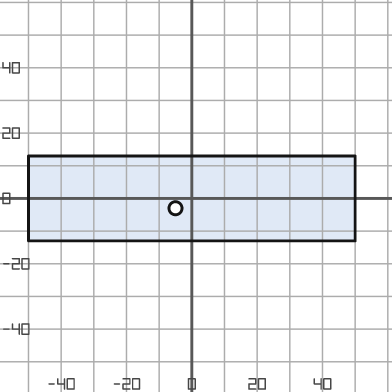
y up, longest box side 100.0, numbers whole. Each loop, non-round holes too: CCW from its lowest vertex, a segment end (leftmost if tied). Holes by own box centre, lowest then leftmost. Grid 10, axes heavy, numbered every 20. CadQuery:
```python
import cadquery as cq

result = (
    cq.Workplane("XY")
    .moveTo(-50.0, -13.0)
    .lineTo(50.0, -13.0)
    .lineTo(50.0, 13.0)
    .lineTo(-50.0, 13.0)
    .close()
    .moveTo(-5.0, -3.0)
    .circle(2.0)
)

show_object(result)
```